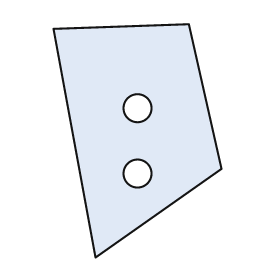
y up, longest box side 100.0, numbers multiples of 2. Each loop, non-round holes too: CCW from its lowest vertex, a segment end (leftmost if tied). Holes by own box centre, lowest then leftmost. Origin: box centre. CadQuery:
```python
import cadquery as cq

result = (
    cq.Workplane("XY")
    .moveTo(-18.0, -50.0)
    .lineTo(36.0, -12.0)
    .lineTo(22.0, 50.0)
    .lineTo(-36.0, 48.0)
    .close()
    .moveTo(0.0, -14.0)
    .circle(6.0)
    .moveTo(0.0, 14.0)
    .circle(6.0)
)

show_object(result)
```